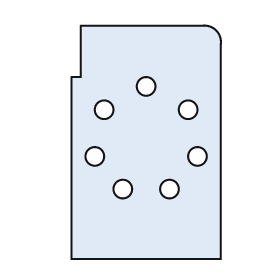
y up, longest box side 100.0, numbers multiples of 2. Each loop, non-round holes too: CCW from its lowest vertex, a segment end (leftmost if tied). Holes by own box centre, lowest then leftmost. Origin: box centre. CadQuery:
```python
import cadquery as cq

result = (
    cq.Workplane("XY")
    .moveTo(-32.0, -50.0)
    .lineTo(32.0, -50.0)
    .lineTo(32.0, 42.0)
    .threePointArc((30.0, 48.0), (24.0, 50.0))
    .lineTo(-28.0, 50.0)
    .lineTo(-28.0, 28.0)
    .lineTo(-32.0, 28.0)
    .close()
    .moveTo(-10.0, -20.0)
    .circle(4.0)
    .moveTo(10.0, -20.0)
    .circle(4.0)
    .moveTo(-22.0, -6.0)
    .circle(4.0)
    .moveTo(22.0, -6.0)
    .circle(4.0)
    .moveTo(-18.0, 14.0)
    .circle(4.0)
    .moveTo(18.0, 14.0)
    .circle(4.0)
    .moveTo(0.0, 24.0)
    .circle(4.0)
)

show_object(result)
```